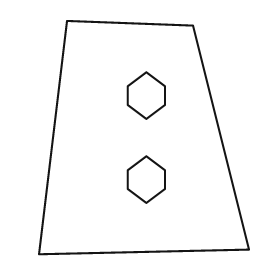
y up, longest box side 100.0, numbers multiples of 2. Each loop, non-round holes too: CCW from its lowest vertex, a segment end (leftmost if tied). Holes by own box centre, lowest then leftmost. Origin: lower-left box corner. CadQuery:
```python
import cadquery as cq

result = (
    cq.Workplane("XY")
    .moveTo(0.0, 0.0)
    .lineTo(90.0, 2.0)
    .lineTo(66.0, 98.0)
    .lineTo(12.0, 100.0)
    .close()
    .moveTo(46.0, 22.0)
    .lineTo(54.0, 28.0)
    .lineTo(54.0, 36.0)
    .lineTo(46.0, 42.0)
    .lineTo(38.0, 36.0)
    .lineTo(38.0, 28.0)
    .close()
    .moveTo(46.0, 58.0)
    .lineTo(54.0, 64.0)
    .lineTo(54.0, 72.0)
    .lineTo(46.0, 78.0)
    .lineTo(38.0, 72.0)
    .lineTo(38.0, 64.0)
    .close()
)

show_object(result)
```